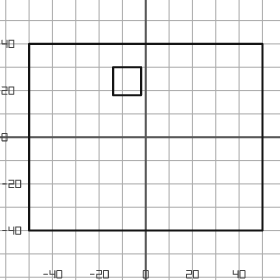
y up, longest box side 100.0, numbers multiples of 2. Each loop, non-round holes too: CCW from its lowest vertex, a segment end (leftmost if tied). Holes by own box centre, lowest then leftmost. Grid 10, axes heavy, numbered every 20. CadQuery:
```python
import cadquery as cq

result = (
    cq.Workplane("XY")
    .moveTo(-50.0, -40.0)
    .lineTo(50.0, -40.0)
    .lineTo(50.0, 40.0)
    .lineTo(-50.0, 40.0)
    .close()
    .moveTo(-14.0, 18.0)
    .lineTo(-2.0, 18.0)
    .lineTo(-2.0, 30.0)
    .lineTo(-14.0, 30.0)
    .close()
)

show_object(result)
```